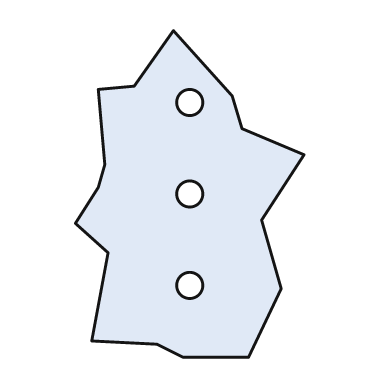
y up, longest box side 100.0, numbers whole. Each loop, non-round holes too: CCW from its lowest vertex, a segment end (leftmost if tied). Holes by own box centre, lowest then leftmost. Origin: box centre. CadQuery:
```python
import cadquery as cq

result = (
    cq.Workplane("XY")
    .moveTo(-2.0, -50.0)
    .lineTo(18.0, -50.0)
    .lineTo(28.0, -29.0)
    .lineTo(22.0, -8.0)
    .lineTo(35.0, 12.0)
    .lineTo(16.0, 20.0)
    .lineTo(13.0, 30.0)
    .lineTo(-5.0, 50.0)
    .lineTo(-17.0, 33.0)
    .lineTo(-28.0, 32.0)
    .lineTo(-26.0, 9.0)
    .lineTo(-28.0, 2.0)
    .lineTo(-35.0, -9.0)
    .lineTo(-25.0, -18.0)
    .lineTo(-30.0, -45.0)
    .lineTo(-10.0, -46.0)
    .close()
    .moveTo(0.0, -28.0)
    .circle(4.0)
    .moveTo(0.0, 0.0)
    .circle(4.0)
    .moveTo(0.0, 28.0)
    .circle(4.0)
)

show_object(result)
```